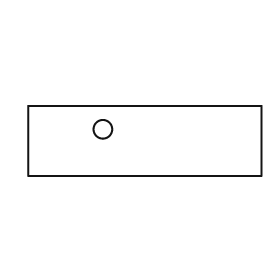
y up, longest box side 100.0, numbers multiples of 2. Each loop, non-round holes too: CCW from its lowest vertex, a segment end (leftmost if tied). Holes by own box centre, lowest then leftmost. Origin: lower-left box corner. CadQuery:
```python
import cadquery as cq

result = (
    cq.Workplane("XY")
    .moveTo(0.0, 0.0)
    .lineTo(100.0, 0.0)
    .lineTo(100.0, 30.0)
    .lineTo(0.0, 30.0)
    .close()
    .moveTo(32.0, 20.0)
    .circle(4.0)
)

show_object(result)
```